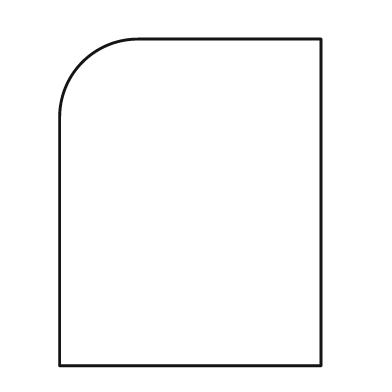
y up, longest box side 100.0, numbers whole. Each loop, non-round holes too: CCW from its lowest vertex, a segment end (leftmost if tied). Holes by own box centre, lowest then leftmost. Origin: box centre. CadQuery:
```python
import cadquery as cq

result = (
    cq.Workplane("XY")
    .moveTo(-40.0, -50.0)
    .lineTo(40.0, -50.0)
    .lineTo(40.0, 50.0)
    .lineTo(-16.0, 50.0)
    .threePointArc((-33.0, 43.0), (-40.0, 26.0))
    .close()
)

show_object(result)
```